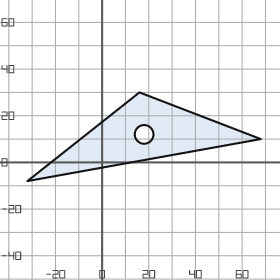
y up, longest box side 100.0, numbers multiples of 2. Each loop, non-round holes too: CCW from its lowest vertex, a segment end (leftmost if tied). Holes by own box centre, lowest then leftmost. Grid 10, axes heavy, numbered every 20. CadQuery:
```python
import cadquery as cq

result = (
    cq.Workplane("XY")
    .moveTo(-32.0, -8.0)
    .lineTo(68.0, 10.0)
    .lineTo(16.0, 30.0)
    .close()
    .moveTo(18.0, 12.0)
    .circle(4.0)
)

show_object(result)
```